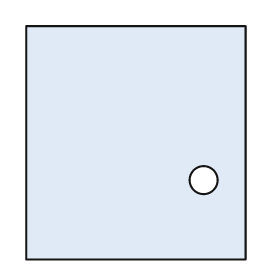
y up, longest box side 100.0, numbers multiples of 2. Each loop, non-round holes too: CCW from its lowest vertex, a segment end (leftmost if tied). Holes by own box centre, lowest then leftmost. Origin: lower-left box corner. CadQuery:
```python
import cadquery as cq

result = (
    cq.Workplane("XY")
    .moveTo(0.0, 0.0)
    .lineTo(94.0, 0.0)
    .lineTo(94.0, 100.0)
    .lineTo(0.0, 100.0)
    .close()
    .moveTo(76.0, 34.0)
    .circle(6.0)
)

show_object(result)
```